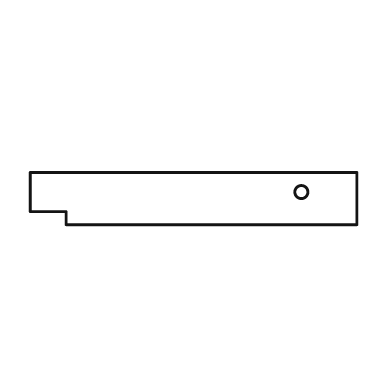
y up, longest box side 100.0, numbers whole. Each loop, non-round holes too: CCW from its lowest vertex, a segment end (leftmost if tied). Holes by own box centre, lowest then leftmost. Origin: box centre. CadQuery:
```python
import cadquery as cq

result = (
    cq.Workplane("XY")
    .moveTo(-39.0, -8.0)
    .lineTo(50.0, -8.0)
    .lineTo(50.0, 8.0)
    .lineTo(-50.0, 8.0)
    .lineTo(-50.0, -4.0)
    .lineTo(-39.0, -4.0)
    .close()
    .moveTo(33.0, 2.0)
    .circle(2.0)
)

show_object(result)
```